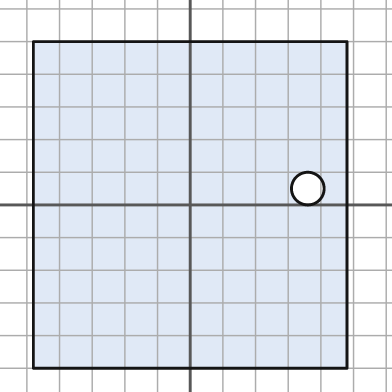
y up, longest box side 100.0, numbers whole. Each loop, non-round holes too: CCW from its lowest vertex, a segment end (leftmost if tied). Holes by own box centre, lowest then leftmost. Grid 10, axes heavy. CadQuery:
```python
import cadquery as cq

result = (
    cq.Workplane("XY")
    .moveTo(-48.0, -50.0)
    .lineTo(48.0, -50.0)
    .lineTo(48.0, 50.0)
    .lineTo(-48.0, 50.0)
    .close()
    .moveTo(36.0, 5.0)
    .circle(5.0)
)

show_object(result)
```